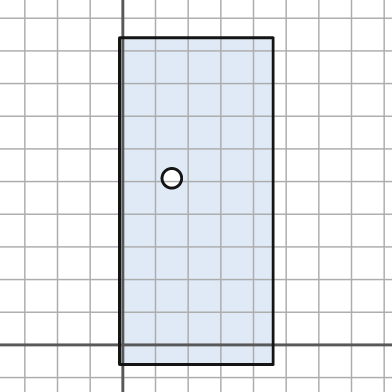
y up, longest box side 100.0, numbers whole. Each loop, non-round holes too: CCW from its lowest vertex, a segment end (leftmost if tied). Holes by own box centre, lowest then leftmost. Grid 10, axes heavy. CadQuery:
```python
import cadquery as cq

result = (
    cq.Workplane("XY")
    .moveTo(-1.0, -6.0)
    .lineTo(46.0, -6.0)
    .lineTo(46.0, 94.0)
    .lineTo(-1.0, 94.0)
    .close()
    .moveTo(15.0, 51.0)
    .circle(3.0)
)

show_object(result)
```